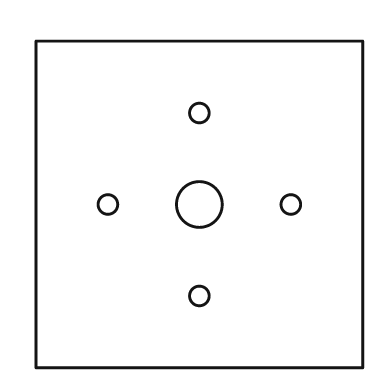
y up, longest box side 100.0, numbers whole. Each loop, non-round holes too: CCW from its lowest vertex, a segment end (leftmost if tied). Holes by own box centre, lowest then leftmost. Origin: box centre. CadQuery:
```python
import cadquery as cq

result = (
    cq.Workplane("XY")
    .moveTo(-50.0, -50.0)
    .lineTo(50.0, -50.0)
    .lineTo(50.0, 50.0)
    .lineTo(-50.0, 50.0)
    .close()
    .moveTo(0.0, -28.0)
    .circle(3.0)
    .moveTo(-28.0, 0.0)
    .circle(3.0)
    .moveTo(0.0, 0.0)
    .circle(7.0)
    .moveTo(28.0, 0.0)
    .circle(3.0)
    .moveTo(0.0, 28.0)
    .circle(3.0)
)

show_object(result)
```